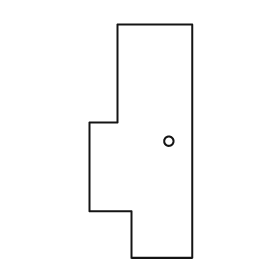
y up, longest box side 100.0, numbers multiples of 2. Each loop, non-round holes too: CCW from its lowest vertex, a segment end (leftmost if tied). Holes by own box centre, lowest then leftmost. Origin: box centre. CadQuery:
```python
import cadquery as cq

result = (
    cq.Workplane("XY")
    .moveTo(-4.0, -50.0)
    .lineTo(22.0, -50.0)
    .lineTo(22.0, 50.0)
    .lineTo(-10.0, 50.0)
    .lineTo(-10.0, 8.0)
    .lineTo(-22.0, 8.0)
    .lineTo(-22.0, -30.0)
    .lineTo(-4.0, -30.0)
    .close()
    .moveTo(12.0, 0.0)
    .circle(2.0)
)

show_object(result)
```